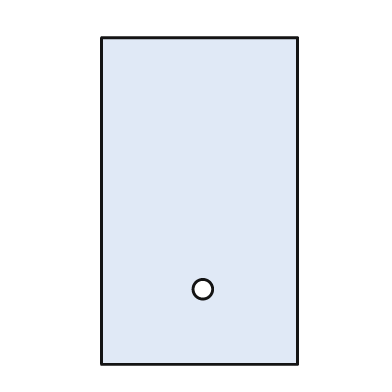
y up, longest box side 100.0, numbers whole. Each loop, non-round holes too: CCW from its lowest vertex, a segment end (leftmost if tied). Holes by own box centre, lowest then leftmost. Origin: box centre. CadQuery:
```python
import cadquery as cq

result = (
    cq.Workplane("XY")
    .moveTo(-30.0, -50.0)
    .lineTo(30.0, -50.0)
    .lineTo(30.0, 50.0)
    .lineTo(-30.0, 50.0)
    .close()
    .moveTo(1.0, -27.0)
    .circle(3.0)
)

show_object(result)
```